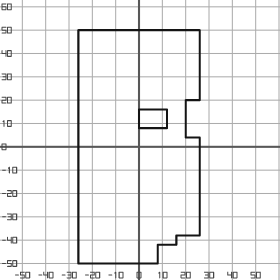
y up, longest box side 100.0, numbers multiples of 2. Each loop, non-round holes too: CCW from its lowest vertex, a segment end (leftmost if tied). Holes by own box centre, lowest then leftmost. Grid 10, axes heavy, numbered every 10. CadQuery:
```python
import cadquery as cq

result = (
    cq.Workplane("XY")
    .moveTo(-26.0, -50.0)
    .lineTo(8.0, -50.0)
    .lineTo(8.0, -42.0)
    .lineTo(16.0, -42.0)
    .lineTo(16.0, -38.0)
    .lineTo(26.0, -38.0)
    .lineTo(26.0, 4.0)
    .lineTo(20.0, 4.0)
    .lineTo(20.0, 20.0)
    .lineTo(26.0, 20.0)
    .lineTo(26.0, 50.0)
    .lineTo(-26.0, 50.0)
    .close()
    .moveTo(0.0, 8.0)
    .lineTo(12.0, 8.0)
    .lineTo(12.0, 16.0)
    .lineTo(0.0, 16.0)
    .close()
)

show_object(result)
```